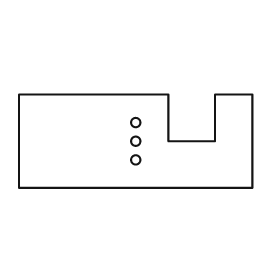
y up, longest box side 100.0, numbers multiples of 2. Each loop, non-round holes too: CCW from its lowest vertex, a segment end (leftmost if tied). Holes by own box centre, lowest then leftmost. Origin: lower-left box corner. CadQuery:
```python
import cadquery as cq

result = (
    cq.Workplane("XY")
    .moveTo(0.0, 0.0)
    .lineTo(100.0, 0.0)
    .lineTo(100.0, 40.0)
    .lineTo(84.0, 40.0)
    .lineTo(84.0, 20.0)
    .lineTo(64.0, 20.0)
    .lineTo(64.0, 40.0)
    .lineTo(0.0, 40.0)
    .close()
    .moveTo(50.0, 12.0)
    .circle(2.0)
    .moveTo(50.0, 20.0)
    .circle(2.0)
    .moveTo(50.0, 28.0)
    .circle(2.0)
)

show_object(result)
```